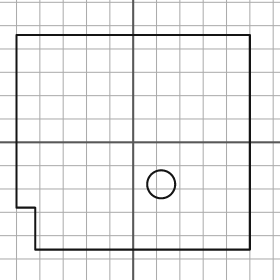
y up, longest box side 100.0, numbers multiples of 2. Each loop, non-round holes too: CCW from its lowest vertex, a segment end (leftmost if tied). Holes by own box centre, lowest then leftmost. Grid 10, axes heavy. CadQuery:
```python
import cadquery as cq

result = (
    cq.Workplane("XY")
    .moveTo(-42.0, -46.0)
    .lineTo(50.0, -46.0)
    .lineTo(50.0, 46.0)
    .lineTo(-50.0, 46.0)
    .lineTo(-50.0, -28.0)
    .lineTo(-42.0, -28.0)
    .close()
    .moveTo(12.0, -18.0)
    .circle(6.0)
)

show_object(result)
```